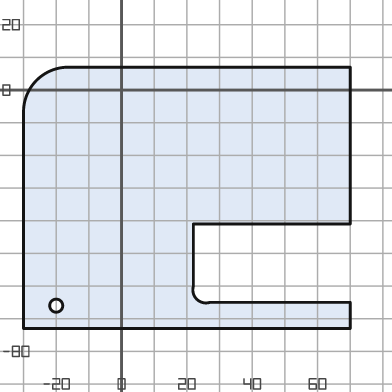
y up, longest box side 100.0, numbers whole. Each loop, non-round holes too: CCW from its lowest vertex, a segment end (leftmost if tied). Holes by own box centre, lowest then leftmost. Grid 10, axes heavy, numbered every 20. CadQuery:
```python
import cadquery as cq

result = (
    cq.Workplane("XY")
    .moveTo(-30.0, -73.0)
    .lineTo(70.0, -73.0)
    .lineTo(70.0, -65.0)
    .lineTo(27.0, -65.0)
    .threePointArc((23.0, -64.0), (22.0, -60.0))
    .lineTo(22.0, -41.0)
    .lineTo(70.0, -41.0)
    .lineTo(70.0, 7.0)
    .lineTo(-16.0, 7.0)
    .threePointArc((-26.0, 3.0), (-30.0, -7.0))
    .close()
    .moveTo(-20.0, -66.0)
    .circle(2.0)
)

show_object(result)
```